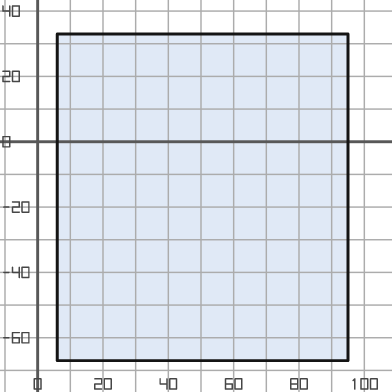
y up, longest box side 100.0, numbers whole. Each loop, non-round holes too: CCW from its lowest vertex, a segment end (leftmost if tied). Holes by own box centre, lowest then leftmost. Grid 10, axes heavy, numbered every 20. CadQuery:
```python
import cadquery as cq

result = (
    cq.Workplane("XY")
    .moveTo(6.0, -67.0)
    .lineTo(95.0, -67.0)
    .lineTo(95.0, 33.0)
    .lineTo(6.0, 33.0)
    .close()
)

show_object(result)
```